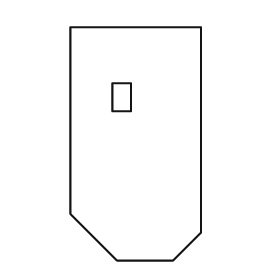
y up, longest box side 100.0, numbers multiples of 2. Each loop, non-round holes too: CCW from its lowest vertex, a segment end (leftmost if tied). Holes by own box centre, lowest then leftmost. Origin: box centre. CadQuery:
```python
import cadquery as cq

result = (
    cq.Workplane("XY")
    .moveTo(-8.0, -50.0)
    .lineTo(16.0, -50.0)
    .lineTo(28.0, -38.0)
    .lineTo(28.0, 50.0)
    .lineTo(-28.0, 50.0)
    .lineTo(-28.0, -30.0)
    .close()
    .moveTo(-10.0, 14.0)
    .lineTo(-2.0, 14.0)
    .lineTo(-2.0, 26.0)
    .lineTo(-10.0, 26.0)
    .close()
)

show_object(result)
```